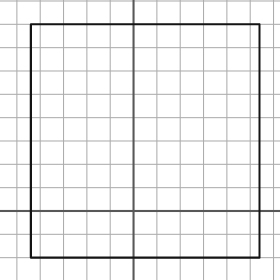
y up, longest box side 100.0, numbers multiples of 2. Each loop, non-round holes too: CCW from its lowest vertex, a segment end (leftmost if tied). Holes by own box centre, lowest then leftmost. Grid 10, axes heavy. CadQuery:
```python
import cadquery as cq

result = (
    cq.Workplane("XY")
    .moveTo(-44.0, -20.0)
    .lineTo(54.0, -20.0)
    .lineTo(54.0, 80.0)
    .lineTo(-44.0, 80.0)
    .close()
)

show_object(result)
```